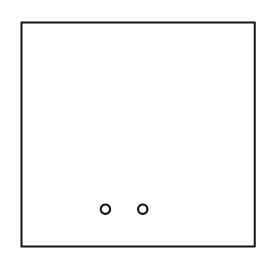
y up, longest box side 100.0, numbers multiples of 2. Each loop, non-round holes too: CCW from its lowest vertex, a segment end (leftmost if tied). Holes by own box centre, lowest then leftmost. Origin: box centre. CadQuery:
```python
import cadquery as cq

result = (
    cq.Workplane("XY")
    .moveTo(-50.0, -48.0)
    .lineTo(50.0, -48.0)
    .lineTo(50.0, 48.0)
    .lineTo(-50.0, 48.0)
    .close()
    .moveTo(-14.0, -32.0)
    .circle(2.0)
    .moveTo(2.0, -32.0)
    .circle(2.0)
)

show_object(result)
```